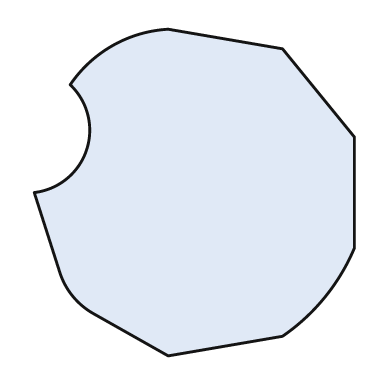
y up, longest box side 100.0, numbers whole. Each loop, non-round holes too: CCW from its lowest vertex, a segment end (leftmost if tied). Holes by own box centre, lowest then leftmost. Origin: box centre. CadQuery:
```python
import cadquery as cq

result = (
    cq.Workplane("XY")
    .moveTo(-8.0, -50.0)
    .lineTo(27.0, -44.0)
    .threePointArc((40.0, -32.0), (49.0, -17.0))
    .lineTo(49.0, 17.0)
    .lineTo(27.0, 44.0)
    .lineTo(-8.0, 50.0)
    .threePointArc((-25.0, 45.0), (-38.0, 33.0))
    .threePointArc((-33.0, 13.0), (-49.0, 0.0))
    .lineTo(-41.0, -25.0)
    .threePointArc((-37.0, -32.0), (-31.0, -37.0))
    .close()
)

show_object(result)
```